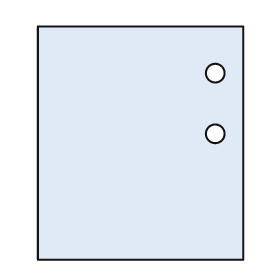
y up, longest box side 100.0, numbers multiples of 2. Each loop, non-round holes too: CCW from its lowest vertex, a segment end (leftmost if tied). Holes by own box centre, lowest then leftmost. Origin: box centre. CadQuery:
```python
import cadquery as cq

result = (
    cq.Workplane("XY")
    .moveTo(-44.0, -50.0)
    .lineTo(44.0, -50.0)
    .lineTo(44.0, 50.0)
    .lineTo(-44.0, 50.0)
    .close()
    .moveTo(32.0, 4.0)
    .circle(4.0)
    .moveTo(32.0, 30.0)
    .circle(4.0)
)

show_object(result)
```